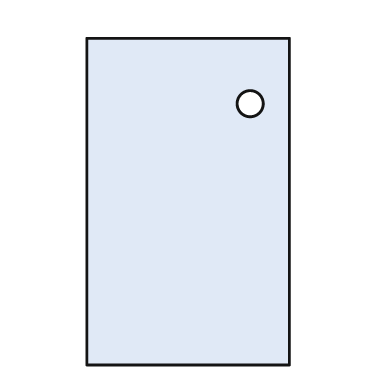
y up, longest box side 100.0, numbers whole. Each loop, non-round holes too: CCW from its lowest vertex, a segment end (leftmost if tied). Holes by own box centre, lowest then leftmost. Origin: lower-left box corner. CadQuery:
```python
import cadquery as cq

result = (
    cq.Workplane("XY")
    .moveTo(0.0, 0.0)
    .lineTo(62.0, 0.0)
    .lineTo(62.0, 100.0)
    .lineTo(0.0, 100.0)
    .close()
    .moveTo(50.0, 80.0)
    .circle(4.0)
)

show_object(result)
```